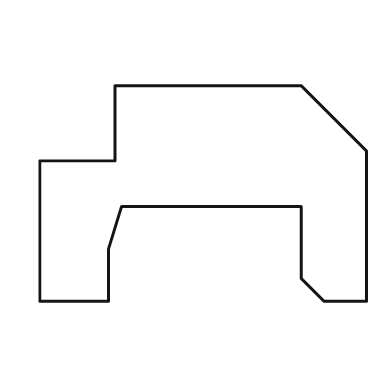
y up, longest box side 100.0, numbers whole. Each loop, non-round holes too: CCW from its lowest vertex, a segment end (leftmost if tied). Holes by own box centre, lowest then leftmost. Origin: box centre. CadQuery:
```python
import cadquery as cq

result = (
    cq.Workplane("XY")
    .moveTo(-50.0, -33.0)
    .lineTo(-29.0, -33.0)
    .lineTo(-29.0, -17.0)
    .lineTo(-25.0, -4.0)
    .lineTo(30.0, -4.0)
    .lineTo(30.0, -26.0)
    .lineTo(37.0, -33.0)
    .lineTo(50.0, -33.0)
    .lineTo(50.0, 13.0)
    .lineTo(30.0, 33.0)
    .lineTo(-27.0, 33.0)
    .lineTo(-27.0, 10.0)
    .lineTo(-50.0, 10.0)
    .close()
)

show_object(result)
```